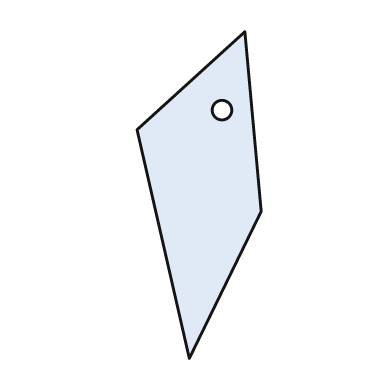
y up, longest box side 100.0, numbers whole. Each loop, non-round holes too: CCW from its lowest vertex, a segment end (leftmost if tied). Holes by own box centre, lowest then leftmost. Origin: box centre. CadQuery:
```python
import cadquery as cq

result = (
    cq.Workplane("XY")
    .moveTo(-3.0, -50.0)
    .lineTo(19.0, -5.0)
    .lineTo(14.0, 50.0)
    .lineTo(-19.0, 20.0)
    .close()
    .moveTo(7.0, 26.0)
    .circle(3.0)
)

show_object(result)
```